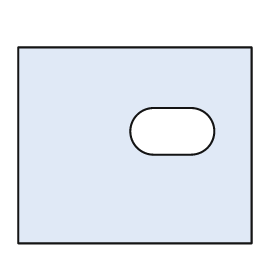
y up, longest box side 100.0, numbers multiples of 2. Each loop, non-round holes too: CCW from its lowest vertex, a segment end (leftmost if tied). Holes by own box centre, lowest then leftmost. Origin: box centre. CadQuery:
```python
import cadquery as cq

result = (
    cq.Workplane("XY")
    .moveTo(-50.0, -42.0)
    .lineTo(50.0, -42.0)
    .lineTo(50.0, 42.0)
    .lineTo(-50.0, 42.0)
    .close()
    .moveTo(8.0, -4.0)
    .lineTo(24.0, -4.0)
    .threePointArc((34.0, 6.0), (24.0, 16.0))
    .lineTo(8.0, 16.0)
    .threePointArc((-2.0, 6.0), (8.0, -4.0))
    .close()
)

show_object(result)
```